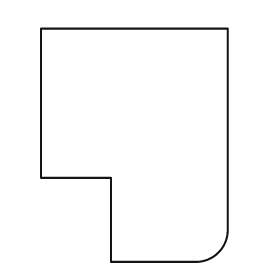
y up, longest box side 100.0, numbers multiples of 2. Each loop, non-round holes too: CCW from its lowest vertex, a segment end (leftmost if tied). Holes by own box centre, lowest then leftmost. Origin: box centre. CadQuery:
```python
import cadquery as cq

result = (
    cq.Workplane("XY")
    .moveTo(-10.0, -50.0)
    .lineTo(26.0, -50.0)
    .threePointArc((36.0, -46.0), (40.0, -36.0))
    .lineTo(40.0, 50.0)
    .lineTo(-40.0, 50.0)
    .lineTo(-40.0, -14.0)
    .lineTo(-10.0, -14.0)
    .close()
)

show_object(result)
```